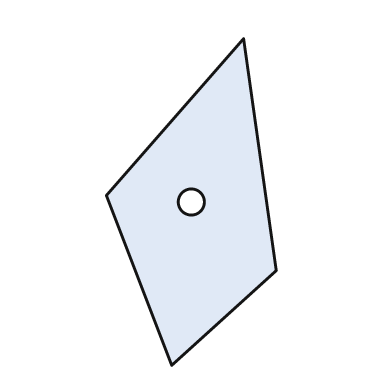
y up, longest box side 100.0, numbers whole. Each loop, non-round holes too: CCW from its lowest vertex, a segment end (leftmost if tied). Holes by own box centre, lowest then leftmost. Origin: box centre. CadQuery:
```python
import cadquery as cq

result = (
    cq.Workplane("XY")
    .moveTo(-6.0, -50.0)
    .lineTo(26.0, -21.0)
    .lineTo(16.0, 50.0)
    .lineTo(-26.0, 2.0)
    .close()
    .moveTo(0.0, 0.0)
    .circle(4.0)
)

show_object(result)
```